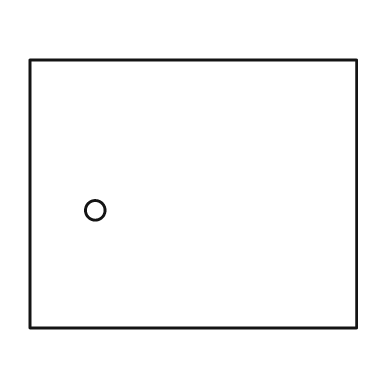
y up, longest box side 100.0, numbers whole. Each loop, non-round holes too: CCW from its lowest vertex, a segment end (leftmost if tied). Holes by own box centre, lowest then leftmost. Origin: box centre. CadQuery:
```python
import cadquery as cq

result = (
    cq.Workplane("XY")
    .moveTo(-50.0, -41.0)
    .lineTo(50.0, -41.0)
    .lineTo(50.0, 41.0)
    .lineTo(-50.0, 41.0)
    .close()
    .moveTo(-30.0, -5.0)
    .circle(3.0)
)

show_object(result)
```